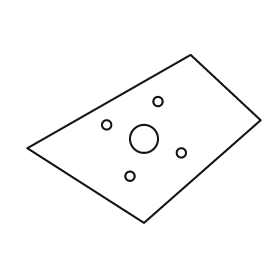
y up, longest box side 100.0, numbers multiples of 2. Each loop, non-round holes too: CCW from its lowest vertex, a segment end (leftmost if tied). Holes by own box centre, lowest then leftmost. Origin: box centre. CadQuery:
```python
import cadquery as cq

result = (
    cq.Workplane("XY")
    .moveTo(0.0, -36.0)
    .lineTo(50.0, 8.0)
    .lineTo(20.0, 36.0)
    .lineTo(-50.0, -4.0)
    .close()
    .moveTo(-6.0, -16.0)
    .circle(2.0)
    .moveTo(16.0, -6.0)
    .circle(2.0)
    .moveTo(0.0, 0.0)
    .circle(6.0)
    .moveTo(-16.0, 6.0)
    .circle(2.0)
    .moveTo(6.0, 16.0)
    .circle(2.0)
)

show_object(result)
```